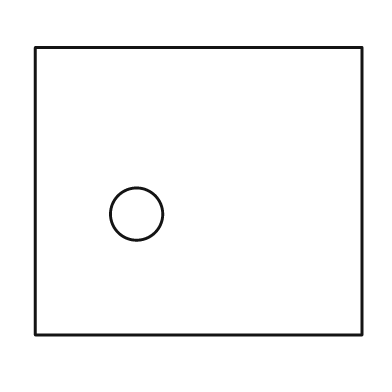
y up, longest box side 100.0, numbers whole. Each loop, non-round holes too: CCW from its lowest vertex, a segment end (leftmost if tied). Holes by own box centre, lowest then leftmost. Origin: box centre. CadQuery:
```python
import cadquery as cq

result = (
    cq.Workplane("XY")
    .moveTo(-50.0, -44.0)
    .lineTo(50.0, -44.0)
    .lineTo(50.0, 44.0)
    .lineTo(-50.0, 44.0)
    .close()
    .moveTo(-19.0, -7.0)
    .circle(8.0)
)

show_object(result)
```